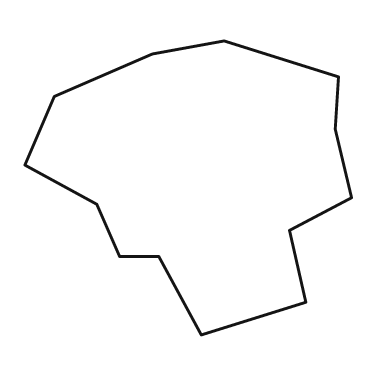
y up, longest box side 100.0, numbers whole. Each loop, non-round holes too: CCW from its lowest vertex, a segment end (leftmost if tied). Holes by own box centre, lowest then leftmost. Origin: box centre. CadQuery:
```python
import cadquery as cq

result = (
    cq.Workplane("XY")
    .moveTo(4.0, -45.0)
    .lineTo(36.0, -35.0)
    .lineTo(31.0, -13.0)
    .lineTo(50.0, -3.0)
    .lineTo(45.0, 18.0)
    .lineTo(46.0, 34.0)
    .lineTo(11.0, 45.0)
    .lineTo(-11.0, 41.0)
    .lineTo(-41.0, 28.0)
    .lineTo(-50.0, 7.0)
    .lineTo(-28.0, -5.0)
    .lineTo(-21.0, -21.0)
    .lineTo(-9.0, -21.0)
    .close()
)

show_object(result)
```